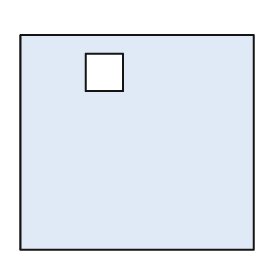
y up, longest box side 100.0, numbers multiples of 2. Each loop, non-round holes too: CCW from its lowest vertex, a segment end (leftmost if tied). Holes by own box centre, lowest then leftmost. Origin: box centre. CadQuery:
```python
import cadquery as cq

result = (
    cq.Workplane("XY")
    .moveTo(-50.0, -46.0)
    .lineTo(50.0, -46.0)
    .lineTo(50.0, 46.0)
    .lineTo(-50.0, 46.0)
    .close()
    .moveTo(-22.0, 22.0)
    .lineTo(-6.0, 22.0)
    .lineTo(-6.0, 38.0)
    .lineTo(-22.0, 38.0)
    .close()
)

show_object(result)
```